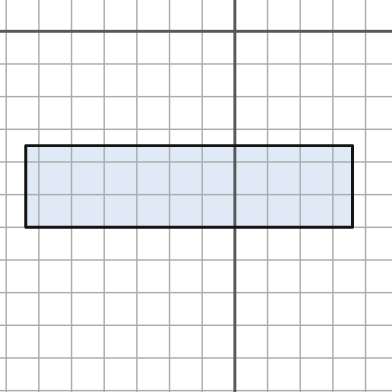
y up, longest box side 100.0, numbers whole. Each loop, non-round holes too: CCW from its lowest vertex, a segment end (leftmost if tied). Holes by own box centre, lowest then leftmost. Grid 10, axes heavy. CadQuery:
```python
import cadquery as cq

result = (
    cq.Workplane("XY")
    .moveTo(-64.0, -60.0)
    .lineTo(36.0, -60.0)
    .lineTo(36.0, -35.0)
    .lineTo(-64.0, -35.0)
    .close()
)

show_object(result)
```